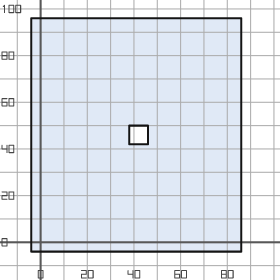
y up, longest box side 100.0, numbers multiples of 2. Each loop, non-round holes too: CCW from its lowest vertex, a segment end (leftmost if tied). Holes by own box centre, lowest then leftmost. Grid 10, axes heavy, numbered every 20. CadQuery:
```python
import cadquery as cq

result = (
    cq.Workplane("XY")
    .moveTo(-4.0, -4.0)
    .lineTo(86.0, -4.0)
    .lineTo(86.0, 96.0)
    .lineTo(-4.0, 96.0)
    .close()
    .moveTo(38.0, 42.0)
    .lineTo(46.0, 42.0)
    .lineTo(46.0, 50.0)
    .lineTo(38.0, 50.0)
    .close()
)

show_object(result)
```